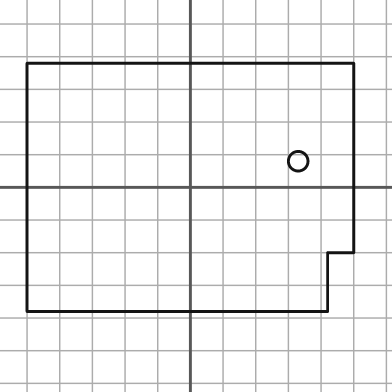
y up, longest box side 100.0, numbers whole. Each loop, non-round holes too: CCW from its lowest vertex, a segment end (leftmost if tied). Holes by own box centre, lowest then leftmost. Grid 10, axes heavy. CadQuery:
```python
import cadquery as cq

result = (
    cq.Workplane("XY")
    .moveTo(-50.0, -38.0)
    .lineTo(42.0, -38.0)
    .lineTo(42.0, -20.0)
    .lineTo(50.0, -20.0)
    .lineTo(50.0, 38.0)
    .lineTo(-50.0, 38.0)
    .close()
    .moveTo(33.0, 8.0)
    .circle(3.0)
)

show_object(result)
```